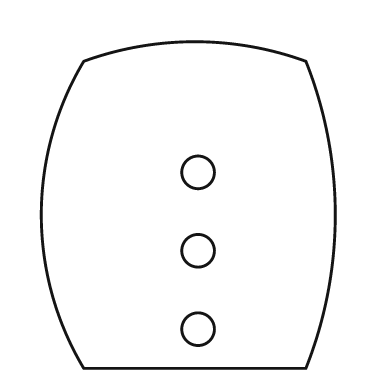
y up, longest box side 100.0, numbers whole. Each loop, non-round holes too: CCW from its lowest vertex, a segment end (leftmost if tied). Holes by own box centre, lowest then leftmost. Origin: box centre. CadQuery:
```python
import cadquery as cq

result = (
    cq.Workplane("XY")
    .moveTo(-32.0, -50.0)
    .lineTo(36.0, -50.0)
    .threePointArc((45.0, -3.0), (36.0, 44.0))
    .threePointArc((2.0, 50.0), (-32.0, 44.0))
    .threePointArc((-45.0, -3.0), (-32.0, -50.0))
    .close()
    .moveTo(3.0, -38.0)
    .circle(5.0)
    .moveTo(3.0, -14.0)
    .circle(5.0)
    .moveTo(3.0, 10.0)
    .circle(5.0)
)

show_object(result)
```